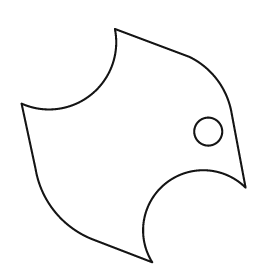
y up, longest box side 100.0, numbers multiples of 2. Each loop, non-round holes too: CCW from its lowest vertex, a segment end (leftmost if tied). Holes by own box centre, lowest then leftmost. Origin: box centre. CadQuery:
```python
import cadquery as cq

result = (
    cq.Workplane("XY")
    .moveTo(8.0, -50.0)
    .threePointArc((14.0, -16.0), (48.0, -18.0))
    .lineTo(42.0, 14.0)
    .threePointArc((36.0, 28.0), (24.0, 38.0))
    .lineTo(-8.0, 50.0)
    .threePointArc((-18.0, 22.0), (-48.0, 18.0))
    .lineTo(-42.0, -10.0)
    .threePointArc((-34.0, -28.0), (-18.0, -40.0))
    .close()
    .moveTo(32.0, 6.0)
    .circle(6.0)
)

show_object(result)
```